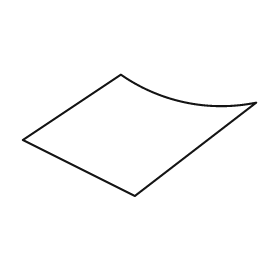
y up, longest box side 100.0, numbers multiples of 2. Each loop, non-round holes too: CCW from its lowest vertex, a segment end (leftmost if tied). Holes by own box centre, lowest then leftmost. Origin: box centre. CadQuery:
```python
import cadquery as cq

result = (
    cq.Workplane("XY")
    .moveTo(-2.0, -26.0)
    .lineTo(50.0, 14.0)
    .threePointArc((20.0, 14.0), (-8.0, 26.0))
    .lineTo(-50.0, -2.0)
    .close()
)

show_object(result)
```